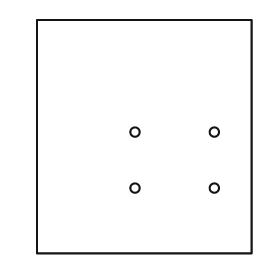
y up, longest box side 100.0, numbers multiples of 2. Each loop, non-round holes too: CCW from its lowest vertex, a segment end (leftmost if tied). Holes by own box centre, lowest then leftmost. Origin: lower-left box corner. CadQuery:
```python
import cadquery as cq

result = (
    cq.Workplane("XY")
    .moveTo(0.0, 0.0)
    .lineTo(92.0, 0.0)
    .lineTo(92.0, 100.0)
    .lineTo(0.0, 100.0)
    .close()
    .moveTo(42.0, 28.0)
    .circle(2.0)
    .moveTo(76.0, 28.0)
    .circle(2.0)
    .moveTo(42.0, 52.0)
    .circle(2.0)
    .moveTo(76.0, 52.0)
    .circle(2.0)
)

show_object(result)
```